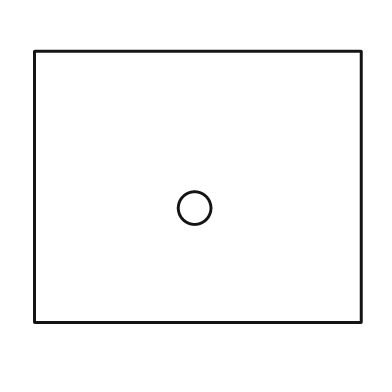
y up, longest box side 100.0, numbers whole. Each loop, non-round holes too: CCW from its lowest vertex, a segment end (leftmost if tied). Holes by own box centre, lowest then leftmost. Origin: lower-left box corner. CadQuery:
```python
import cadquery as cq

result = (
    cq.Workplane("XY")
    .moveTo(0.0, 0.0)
    .lineTo(100.0, 0.0)
    .lineTo(100.0, 83.0)
    .lineTo(0.0, 83.0)
    .close()
    .moveTo(49.0, 35.0)
    .circle(5.0)
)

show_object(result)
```